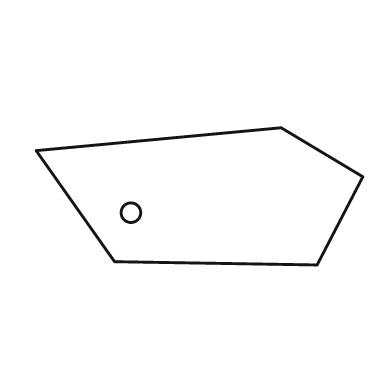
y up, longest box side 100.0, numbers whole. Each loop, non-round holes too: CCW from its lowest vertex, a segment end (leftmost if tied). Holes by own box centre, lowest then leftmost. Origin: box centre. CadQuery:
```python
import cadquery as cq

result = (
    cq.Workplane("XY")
    .moveTo(36.0, -21.0)
    .lineTo(50.0, 6.0)
    .lineTo(25.0, 21.0)
    .lineTo(-50.0, 14.0)
    .lineTo(-26.0, -20.0)
    .close()
    .moveTo(-21.0, -5.0)
    .circle(3.0)
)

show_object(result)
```